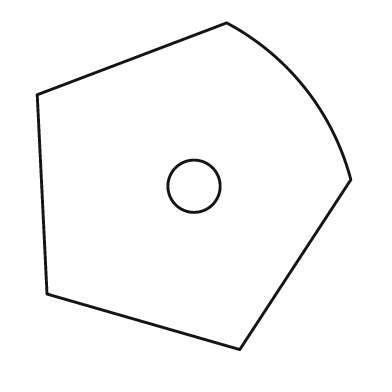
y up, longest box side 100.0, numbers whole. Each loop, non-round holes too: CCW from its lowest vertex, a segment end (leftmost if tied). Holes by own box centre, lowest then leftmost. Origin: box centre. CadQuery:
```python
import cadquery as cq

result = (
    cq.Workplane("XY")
    .moveTo(14.0, -50.0)
    .lineTo(48.0, 2.0)
    .threePointArc((34.0, 30.0), (10.0, 50.0))
    .lineTo(-48.0, 28.0)
    .lineTo(-45.0, -33.0)
    .close()
    .moveTo(0.0, 0.0)
    .circle(8.0)
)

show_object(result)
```